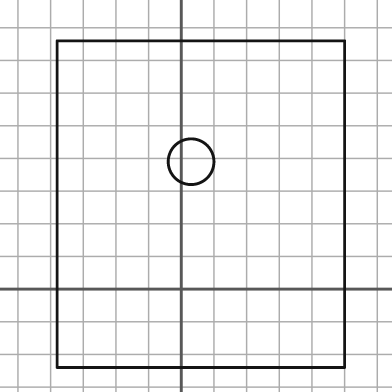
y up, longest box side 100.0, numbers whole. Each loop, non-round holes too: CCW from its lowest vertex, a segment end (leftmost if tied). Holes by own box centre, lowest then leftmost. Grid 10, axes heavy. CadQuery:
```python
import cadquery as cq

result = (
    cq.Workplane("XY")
    .moveTo(-38.0, -24.0)
    .lineTo(50.0, -24.0)
    .lineTo(50.0, 76.0)
    .lineTo(-38.0, 76.0)
    .close()
    .moveTo(3.0, 39.0)
    .circle(7.0)
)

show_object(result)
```